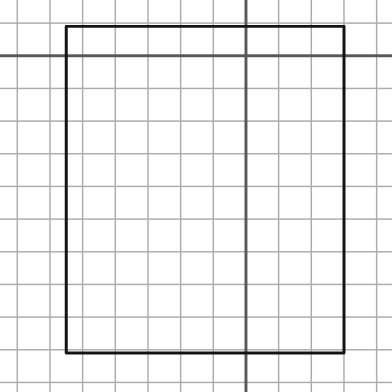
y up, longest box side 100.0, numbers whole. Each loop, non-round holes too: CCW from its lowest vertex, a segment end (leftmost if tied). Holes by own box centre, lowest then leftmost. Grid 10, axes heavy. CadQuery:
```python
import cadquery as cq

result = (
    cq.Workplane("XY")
    .moveTo(-55.0, -91.0)
    .lineTo(30.0, -91.0)
    .lineTo(30.0, 9.0)
    .lineTo(-55.0, 9.0)
    .close()
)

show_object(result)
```